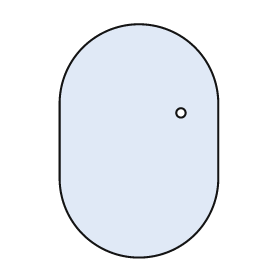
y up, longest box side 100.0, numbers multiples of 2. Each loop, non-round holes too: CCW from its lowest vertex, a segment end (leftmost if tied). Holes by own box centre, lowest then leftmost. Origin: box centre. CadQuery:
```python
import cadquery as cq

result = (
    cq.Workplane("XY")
    .moveTo(-34.0, -16.0)
    .threePointArc((0.0, -50.0), (34.0, -16.0))
    .lineTo(34.0, 16.0)
    .threePointArc((0.0, 50.0), (-34.0, 16.0))
    .close()
    .moveTo(18.0, 12.0)
    .circle(2.0)
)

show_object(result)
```